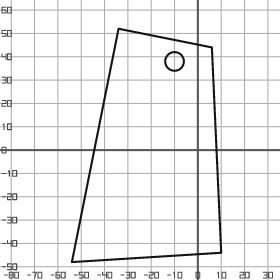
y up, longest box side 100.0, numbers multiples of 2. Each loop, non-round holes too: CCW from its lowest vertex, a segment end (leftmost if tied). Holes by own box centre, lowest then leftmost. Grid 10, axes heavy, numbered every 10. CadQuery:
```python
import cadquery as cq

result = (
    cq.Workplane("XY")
    .moveTo(-54.0, -48.0)
    .lineTo(10.0, -44.0)
    .lineTo(6.0, 44.0)
    .lineTo(-34.0, 52.0)
    .close()
    .moveTo(-10.0, 38.0)
    .circle(4.0)
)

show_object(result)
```